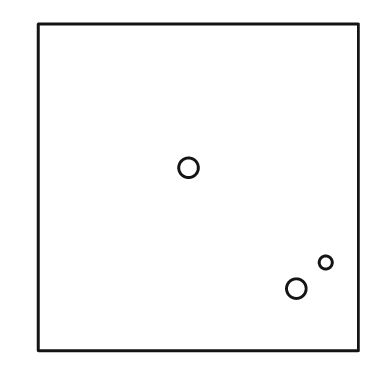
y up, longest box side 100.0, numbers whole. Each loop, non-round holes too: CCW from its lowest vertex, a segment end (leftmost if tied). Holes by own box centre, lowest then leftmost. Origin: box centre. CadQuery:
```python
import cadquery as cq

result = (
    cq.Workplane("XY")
    .moveTo(-49.0, -50.0)
    .lineTo(49.0, -50.0)
    .lineTo(49.0, 50.0)
    .lineTo(-49.0, 50.0)
    .close()
    .moveTo(30.0, -31.0)
    .circle(3.0)
    .moveTo(39.0, -23.0)
    .circle(2.0)
    .moveTo(-3.0, 6.0)
    .circle(3.0)
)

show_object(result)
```